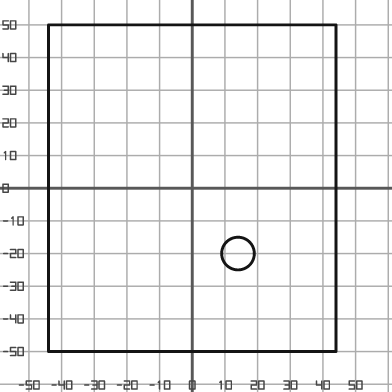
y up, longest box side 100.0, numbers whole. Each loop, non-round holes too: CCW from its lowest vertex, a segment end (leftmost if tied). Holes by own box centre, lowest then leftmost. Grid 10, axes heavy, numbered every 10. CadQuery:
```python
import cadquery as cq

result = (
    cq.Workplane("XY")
    .moveTo(-44.0, -50.0)
    .lineTo(44.0, -50.0)
    .lineTo(44.0, 50.0)
    .lineTo(-44.0, 50.0)
    .close()
    .moveTo(14.0, -20.0)
    .circle(5.0)
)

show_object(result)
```